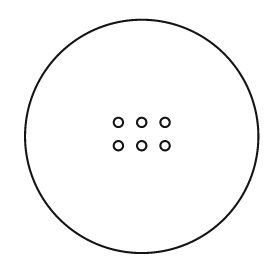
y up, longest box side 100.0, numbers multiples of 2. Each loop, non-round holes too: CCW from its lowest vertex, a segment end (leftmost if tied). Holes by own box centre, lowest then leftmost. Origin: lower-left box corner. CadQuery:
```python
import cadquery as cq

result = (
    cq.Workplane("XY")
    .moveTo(50.0, 50.0)
    .circle(50.0)
    .moveTo(40.0, 46.0)
    .circle(2.0)
    .moveTo(50.0, 46.0)
    .circle(2.0)
    .moveTo(60.0, 46.0)
    .circle(2.0)
    .moveTo(40.0, 56.0)
    .circle(2.0)
    .moveTo(50.0, 56.0)
    .circle(2.0)
    .moveTo(60.0, 56.0)
    .circle(2.0)
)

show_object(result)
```